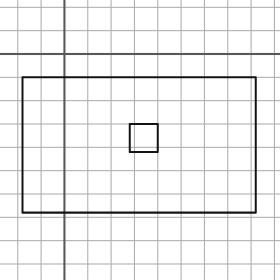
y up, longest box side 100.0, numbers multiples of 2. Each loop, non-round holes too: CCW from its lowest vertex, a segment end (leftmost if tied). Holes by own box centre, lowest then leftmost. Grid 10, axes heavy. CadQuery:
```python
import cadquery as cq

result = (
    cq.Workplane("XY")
    .moveTo(-18.0, -68.0)
    .lineTo(82.0, -68.0)
    .lineTo(82.0, -10.0)
    .lineTo(-18.0, -10.0)
    .close()
    .moveTo(28.0, -42.0)
    .lineTo(40.0, -42.0)
    .lineTo(40.0, -30.0)
    .lineTo(28.0, -30.0)
    .close()
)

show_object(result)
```